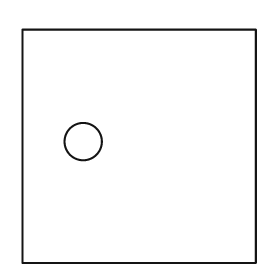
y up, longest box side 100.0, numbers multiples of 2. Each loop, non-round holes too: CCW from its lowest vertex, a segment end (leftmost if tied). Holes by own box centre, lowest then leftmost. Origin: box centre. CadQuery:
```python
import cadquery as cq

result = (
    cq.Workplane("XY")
    .moveTo(-50.0, -50.0)
    .lineTo(50.0, -50.0)
    .lineTo(50.0, 50.0)
    .lineTo(-50.0, 50.0)
    .close()
    .moveTo(-24.0, 2.0)
    .circle(8.0)
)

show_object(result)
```